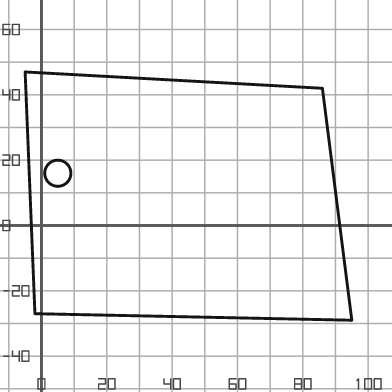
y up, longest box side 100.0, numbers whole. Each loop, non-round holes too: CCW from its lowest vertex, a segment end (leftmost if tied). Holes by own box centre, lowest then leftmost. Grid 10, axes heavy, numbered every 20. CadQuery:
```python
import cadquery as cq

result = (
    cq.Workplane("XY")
    .moveTo(95.0, -29.0)
    .lineTo(86.0, 42.0)
    .lineTo(-5.0, 47.0)
    .lineTo(-2.0, -27.0)
    .close()
    .moveTo(5.0, 16.0)
    .circle(4.0)
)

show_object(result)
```